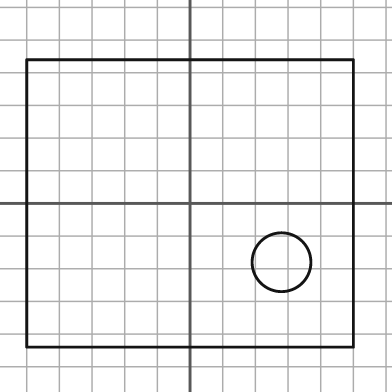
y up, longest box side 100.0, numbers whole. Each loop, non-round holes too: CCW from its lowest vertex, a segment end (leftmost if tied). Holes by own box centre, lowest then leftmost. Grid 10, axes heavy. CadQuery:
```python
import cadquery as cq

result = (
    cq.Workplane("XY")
    .moveTo(-50.0, -44.0)
    .lineTo(50.0, -44.0)
    .lineTo(50.0, 44.0)
    .lineTo(-50.0, 44.0)
    .close()
    .moveTo(28.0, -18.0)
    .circle(9.0)
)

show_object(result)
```